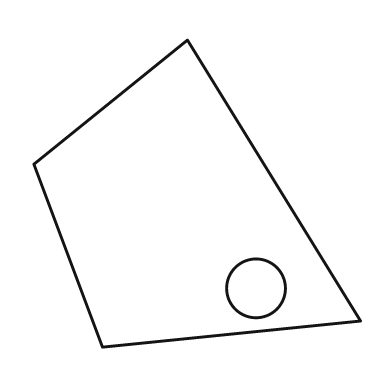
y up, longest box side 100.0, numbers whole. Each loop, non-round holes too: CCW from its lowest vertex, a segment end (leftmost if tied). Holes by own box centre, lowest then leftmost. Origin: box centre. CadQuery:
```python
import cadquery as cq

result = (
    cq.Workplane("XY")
    .moveTo(-29.0, -47.0)
    .lineTo(50.0, -39.0)
    .lineTo(-3.0, 47.0)
    .lineTo(-50.0, 9.0)
    .close()
    .moveTo(18.0, -29.0)
    .circle(9.0)
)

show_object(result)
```